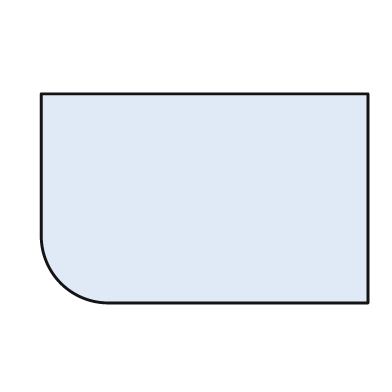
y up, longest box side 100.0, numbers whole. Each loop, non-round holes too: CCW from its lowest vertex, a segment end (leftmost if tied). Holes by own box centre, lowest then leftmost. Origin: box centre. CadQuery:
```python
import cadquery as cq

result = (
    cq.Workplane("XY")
    .moveTo(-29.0, -32.0)
    .lineTo(50.0, -32.0)
    .lineTo(50.0, 32.0)
    .lineTo(-50.0, 32.0)
    .lineTo(-50.0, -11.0)
    .threePointArc((-44.0, -26.0), (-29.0, -32.0))
    .close()
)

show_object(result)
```